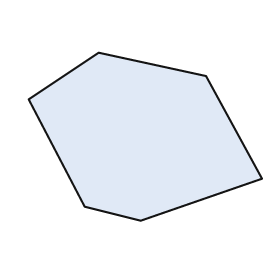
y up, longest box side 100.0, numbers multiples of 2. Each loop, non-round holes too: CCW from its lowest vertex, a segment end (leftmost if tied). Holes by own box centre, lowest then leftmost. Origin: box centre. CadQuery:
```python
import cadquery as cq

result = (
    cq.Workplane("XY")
    .moveTo(-2.0, -36.0)
    .lineTo(50.0, -18.0)
    .lineTo(26.0, 26.0)
    .lineTo(-20.0, 36.0)
    .lineTo(-50.0, 16.0)
    .lineTo(-26.0, -30.0)
    .close()
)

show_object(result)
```